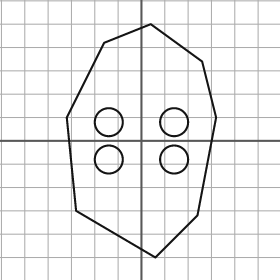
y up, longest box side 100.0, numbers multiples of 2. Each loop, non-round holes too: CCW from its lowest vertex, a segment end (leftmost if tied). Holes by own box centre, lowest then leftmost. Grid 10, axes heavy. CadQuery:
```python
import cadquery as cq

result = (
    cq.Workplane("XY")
    .moveTo(6.0, -50.0)
    .lineTo(24.0, -32.0)
    .lineTo(32.0, 10.0)
    .lineTo(26.0, 34.0)
    .lineTo(4.0, 50.0)
    .lineTo(-16.0, 42.0)
    .lineTo(-32.0, 10.0)
    .lineTo(-28.0, -30.0)
    .close()
    .moveTo(-14.0, -8.0)
    .circle(6.0)
    .moveTo(14.0, -8.0)
    .circle(6.0)
    .moveTo(-14.0, 8.0)
    .circle(6.0)
    .moveTo(14.0, 8.0)
    .circle(6.0)
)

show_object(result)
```